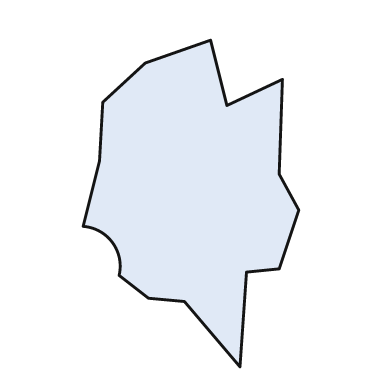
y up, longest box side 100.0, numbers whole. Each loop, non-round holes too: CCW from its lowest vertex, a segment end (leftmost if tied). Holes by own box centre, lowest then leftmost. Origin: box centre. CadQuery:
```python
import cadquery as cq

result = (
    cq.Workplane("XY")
    .moveTo(15.0, -50.0)
    .lineTo(17.0, -21.0)
    .lineTo(27.0, -20.0)
    .lineTo(33.0, -2.0)
    .lineTo(27.0, 9.0)
    .lineTo(28.0, 38.0)
    .lineTo(11.0, 30.0)
    .lineTo(6.0, 50.0)
    .lineTo(-14.0, 43.0)
    .lineTo(-27.0, 31.0)
    .lineTo(-28.0, 13.0)
    .lineTo(-33.0, -7.0)
    .threePointArc((-24.0, -12.0), (-22.0, -22.0))
    .lineTo(-13.0, -29.0)
    .lineTo(-2.0, -30.0)
    .close()
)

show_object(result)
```